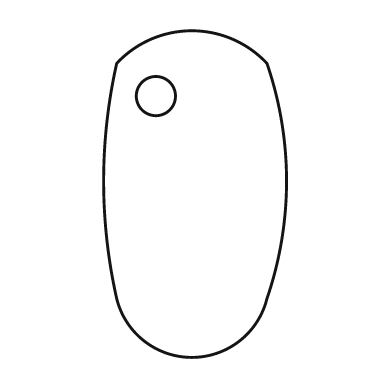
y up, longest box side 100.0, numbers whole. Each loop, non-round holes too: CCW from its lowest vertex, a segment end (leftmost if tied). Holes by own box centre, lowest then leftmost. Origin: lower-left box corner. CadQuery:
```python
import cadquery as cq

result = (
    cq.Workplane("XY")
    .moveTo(4.0, 18.0)
    .threePointArc((27.0, 0.0), (50.0, 18.0))
    .threePointArc((56.0, 54.0), (50.0, 90.0))
    .threePointArc((27.0, 100.0), (4.0, 90.0))
    .threePointArc((0.0, 54.0), (4.0, 18.0))
    .close()
    .moveTo(16.0, 80.0)
    .circle(6.0)
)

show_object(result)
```